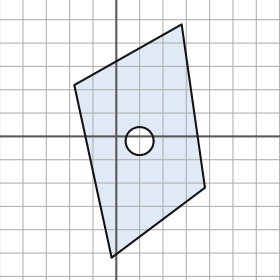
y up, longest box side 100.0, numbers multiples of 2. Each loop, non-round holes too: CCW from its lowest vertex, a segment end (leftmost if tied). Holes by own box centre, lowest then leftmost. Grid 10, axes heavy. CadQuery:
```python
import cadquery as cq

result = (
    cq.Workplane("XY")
    .moveTo(-2.0, -52.0)
    .lineTo(38.0, -22.0)
    .lineTo(28.0, 48.0)
    .lineTo(-18.0, 22.0)
    .close()
    .moveTo(10.0, -2.0)
    .circle(6.0)
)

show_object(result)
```